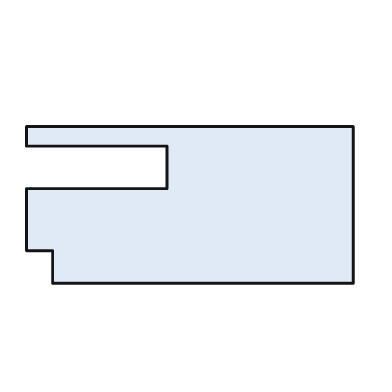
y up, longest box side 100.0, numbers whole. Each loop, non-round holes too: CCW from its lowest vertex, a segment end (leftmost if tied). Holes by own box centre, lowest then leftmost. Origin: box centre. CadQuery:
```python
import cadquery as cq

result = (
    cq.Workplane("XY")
    .moveTo(-42.0, -24.0)
    .lineTo(50.0, -24.0)
    .lineTo(50.0, 24.0)
    .lineTo(-50.0, 24.0)
    .lineTo(-50.0, 18.0)
    .lineTo(-7.0, 18.0)
    .lineTo(-7.0, 5.0)
    .lineTo(-50.0, 5.0)
    .lineTo(-50.0, -14.0)
    .lineTo(-42.0, -14.0)
    .close()
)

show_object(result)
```